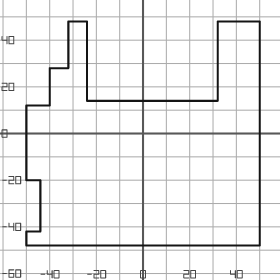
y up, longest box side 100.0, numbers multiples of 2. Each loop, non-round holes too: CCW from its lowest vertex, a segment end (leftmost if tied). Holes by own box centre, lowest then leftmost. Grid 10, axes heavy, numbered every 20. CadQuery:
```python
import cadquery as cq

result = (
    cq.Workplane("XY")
    .moveTo(-50.0, -48.0)
    .lineTo(50.0, -48.0)
    .lineTo(50.0, 48.0)
    .lineTo(32.0, 48.0)
    .lineTo(32.0, 14.0)
    .lineTo(-24.0, 14.0)
    .lineTo(-24.0, 48.0)
    .lineTo(-32.0, 48.0)
    .lineTo(-32.0, 28.0)
    .lineTo(-40.0, 28.0)
    .lineTo(-40.0, 12.0)
    .lineTo(-50.0, 12.0)
    .lineTo(-50.0, -20.0)
    .lineTo(-44.0, -20.0)
    .lineTo(-44.0, -42.0)
    .lineTo(-50.0, -42.0)
    .close()
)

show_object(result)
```